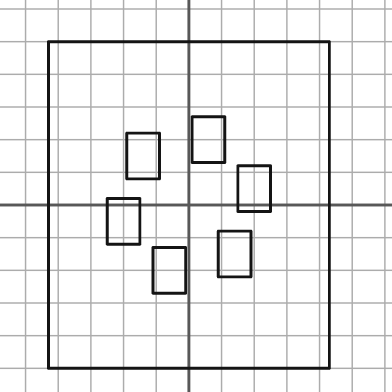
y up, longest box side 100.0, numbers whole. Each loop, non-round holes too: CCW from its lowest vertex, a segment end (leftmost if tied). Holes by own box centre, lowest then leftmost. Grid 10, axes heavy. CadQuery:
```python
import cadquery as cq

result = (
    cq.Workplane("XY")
    .moveTo(-43.0, -50.0)
    .lineTo(43.0, -50.0)
    .lineTo(43.0, 50.0)
    .lineTo(-43.0, 50.0)
    .close()
    .moveTo(-11.0, -27.0)
    .lineTo(-1.0, -27.0)
    .lineTo(-1.0, -13.0)
    .lineTo(-11.0, -13.0)
    .close()
    .moveTo(9.0, -22.0)
    .lineTo(19.0, -22.0)
    .lineTo(19.0, -8.0)
    .lineTo(9.0, -8.0)
    .close()
    .moveTo(-25.0, -12.0)
    .lineTo(-15.0, -12.0)
    .lineTo(-15.0, 2.0)
    .lineTo(-25.0, 2.0)
    .close()
    .moveTo(15.0, -2.0)
    .lineTo(25.0, -2.0)
    .lineTo(25.0, 12.0)
    .lineTo(15.0, 12.0)
    .close()
    .moveTo(-19.0, 8.0)
    .lineTo(-9.0, 8.0)
    .lineTo(-9.0, 22.0)
    .lineTo(-19.0, 22.0)
    .close()
    .moveTo(1.0, 13.0)
    .lineTo(11.0, 13.0)
    .lineTo(11.0, 27.0)
    .lineTo(1.0, 27.0)
    .close()
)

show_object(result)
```